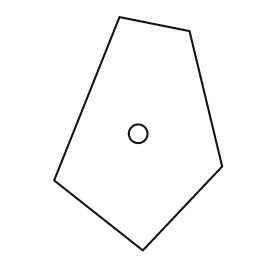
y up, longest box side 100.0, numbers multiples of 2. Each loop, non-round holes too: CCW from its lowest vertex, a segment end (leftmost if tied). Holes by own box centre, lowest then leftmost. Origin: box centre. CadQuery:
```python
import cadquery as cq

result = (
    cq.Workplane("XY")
    .moveTo(2.0, -50.0)
    .lineTo(36.0, -14.0)
    .lineTo(22.0, 44.0)
    .lineTo(-8.0, 50.0)
    .lineTo(-36.0, -20.0)
    .close()
    .moveTo(0.0, 0.0)
    .circle(4.0)
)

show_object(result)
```